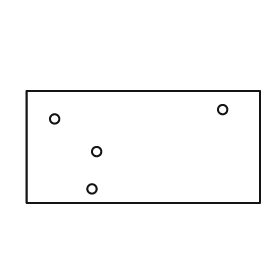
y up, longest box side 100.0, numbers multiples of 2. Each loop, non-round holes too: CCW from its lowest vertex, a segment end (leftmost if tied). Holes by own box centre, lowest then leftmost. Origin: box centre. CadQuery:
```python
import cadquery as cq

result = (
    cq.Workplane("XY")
    .moveTo(-50.0, -24.0)
    .lineTo(50.0, -24.0)
    .lineTo(50.0, 24.0)
    .lineTo(-50.0, 24.0)
    .close()
    .moveTo(-22.0, -18.0)
    .circle(2.0)
    .moveTo(-20.0, -2.0)
    .circle(2.0)
    .moveTo(-38.0, 12.0)
    .circle(2.0)
    .moveTo(34.0, 16.0)
    .circle(2.0)
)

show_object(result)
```